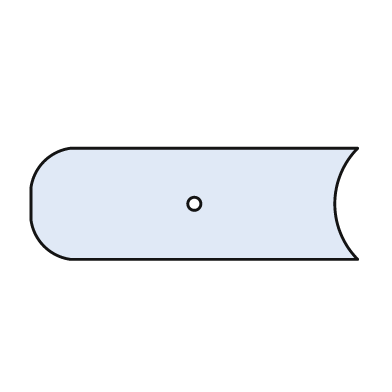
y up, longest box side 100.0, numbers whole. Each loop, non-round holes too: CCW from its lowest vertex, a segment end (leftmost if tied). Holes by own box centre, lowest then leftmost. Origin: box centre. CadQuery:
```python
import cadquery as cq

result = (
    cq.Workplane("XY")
    .moveTo(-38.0, -17.0)
    .lineTo(50.0, -17.0)
    .threePointArc((43.0, 0.0), (50.0, 17.0))
    .lineTo(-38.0, 17.0)
    .threePointArc((-46.0, 13.0), (-50.0, 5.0))
    .lineTo(-50.0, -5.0)
    .threePointArc((-46.0, -13.0), (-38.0, -17.0))
    .close()
    .moveTo(0.0, 0.0)
    .circle(2.0)
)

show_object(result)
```